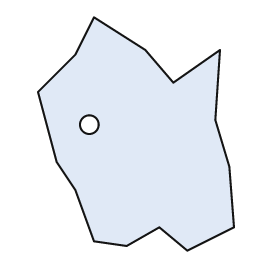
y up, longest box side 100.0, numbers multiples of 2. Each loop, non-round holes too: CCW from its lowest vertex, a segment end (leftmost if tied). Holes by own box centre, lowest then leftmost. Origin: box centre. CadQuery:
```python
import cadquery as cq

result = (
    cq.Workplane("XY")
    .moveTo(22.0, -50.0)
    .lineTo(42.0, -40.0)
    .lineTo(40.0, -14.0)
    .lineTo(34.0, 6.0)
    .lineTo(36.0, 36.0)
    .lineTo(16.0, 22.0)
    .lineTo(4.0, 36.0)
    .lineTo(-18.0, 50.0)
    .lineTo(-26.0, 34.0)
    .lineTo(-42.0, 18.0)
    .lineTo(-34.0, -12.0)
    .lineTo(-26.0, -24.0)
    .lineTo(-18.0, -46.0)
    .lineTo(-4.0, -48.0)
    .lineTo(10.0, -40.0)
    .close()
    .moveTo(-20.0, 4.0)
    .circle(4.0)
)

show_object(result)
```